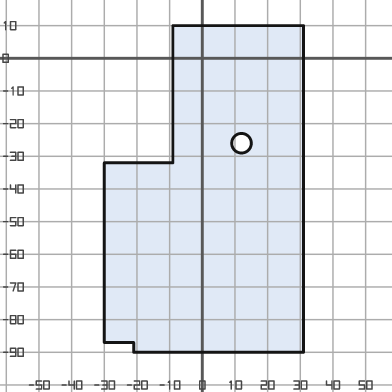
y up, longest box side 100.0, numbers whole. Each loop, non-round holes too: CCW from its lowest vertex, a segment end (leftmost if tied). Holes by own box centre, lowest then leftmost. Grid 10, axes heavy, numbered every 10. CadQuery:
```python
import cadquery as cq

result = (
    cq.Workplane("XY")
    .moveTo(-21.0, -90.0)
    .lineTo(31.0, -90.0)
    .lineTo(31.0, 10.0)
    .lineTo(-9.0, 10.0)
    .lineTo(-9.0, -32.0)
    .lineTo(-30.0, -32.0)
    .lineTo(-30.0, -87.0)
    .lineTo(-21.0, -87.0)
    .close()
    .moveTo(12.0, -26.0)
    .circle(3.0)
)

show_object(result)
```